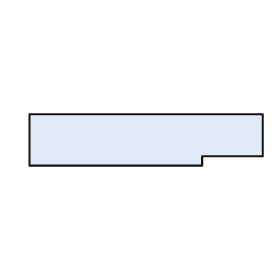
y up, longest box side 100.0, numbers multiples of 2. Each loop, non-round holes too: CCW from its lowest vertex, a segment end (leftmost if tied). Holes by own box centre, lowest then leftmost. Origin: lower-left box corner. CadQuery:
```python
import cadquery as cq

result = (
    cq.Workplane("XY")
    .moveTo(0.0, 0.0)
    .lineTo(74.0, 0.0)
    .lineTo(74.0, 4.0)
    .lineTo(100.0, 4.0)
    .lineTo(100.0, 22.0)
    .lineTo(0.0, 22.0)
    .close()
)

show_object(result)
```